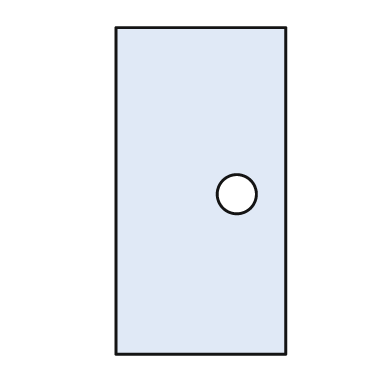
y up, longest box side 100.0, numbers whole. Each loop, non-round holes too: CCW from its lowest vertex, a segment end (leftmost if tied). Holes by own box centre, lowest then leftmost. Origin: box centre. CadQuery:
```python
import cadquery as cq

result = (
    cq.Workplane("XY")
    .moveTo(-26.0, -50.0)
    .lineTo(26.0, -50.0)
    .lineTo(26.0, 50.0)
    .lineTo(-26.0, 50.0)
    .close()
    .moveTo(11.0, -1.0)
    .circle(6.0)
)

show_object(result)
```